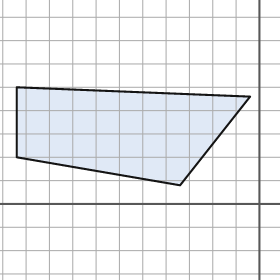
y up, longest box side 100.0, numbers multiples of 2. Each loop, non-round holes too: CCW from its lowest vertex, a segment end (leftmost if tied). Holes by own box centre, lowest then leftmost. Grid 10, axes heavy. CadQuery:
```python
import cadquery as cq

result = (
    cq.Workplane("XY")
    .moveTo(-34.0, 8.0)
    .lineTo(-4.0, 46.0)
    .lineTo(-104.0, 50.0)
    .lineTo(-104.0, 20.0)
    .close()
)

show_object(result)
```